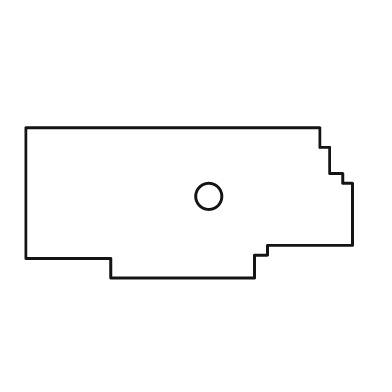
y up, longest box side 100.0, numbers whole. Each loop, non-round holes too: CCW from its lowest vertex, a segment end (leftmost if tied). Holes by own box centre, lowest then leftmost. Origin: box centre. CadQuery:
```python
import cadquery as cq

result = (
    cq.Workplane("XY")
    .moveTo(-24.0, -23.0)
    .lineTo(20.0, -23.0)
    .lineTo(20.0, -16.0)
    .lineTo(24.0, -16.0)
    .lineTo(24.0, -13.0)
    .lineTo(50.0, -13.0)
    .lineTo(50.0, 6.0)
    .lineTo(47.0, 6.0)
    .lineTo(47.0, 9.0)
    .lineTo(43.0, 9.0)
    .lineTo(43.0, 17.0)
    .lineTo(40.0, 17.0)
    .lineTo(40.0, 23.0)
    .lineTo(-50.0, 23.0)
    .lineTo(-50.0, -17.0)
    .lineTo(-24.0, -17.0)
    .close()
    .moveTo(6.0, 2.0)
    .circle(4.0)
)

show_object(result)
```